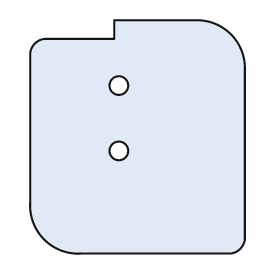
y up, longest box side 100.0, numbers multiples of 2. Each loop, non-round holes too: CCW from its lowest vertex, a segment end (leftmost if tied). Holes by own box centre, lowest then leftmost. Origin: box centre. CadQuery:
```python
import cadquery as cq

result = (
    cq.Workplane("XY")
    .moveTo(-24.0, -50.0)
    .lineTo(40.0, -50.0)
    .threePointArc((44.0, -48.0), (46.0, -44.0))
    .lineTo(46.0, 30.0)
    .threePointArc((40.0, 44.0), (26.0, 50.0))
    .lineTo(-10.0, 50.0)
    .lineTo(-10.0, 42.0)
    .lineTo(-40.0, 42.0)
    .threePointArc((-44.0, 40.0), (-46.0, 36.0))
    .lineTo(-46.0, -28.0)
    .threePointArc((-40.0, -44.0), (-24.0, -50.0))
    .close()
    .moveTo(-8.0, -6.0)
    .circle(4.0)
    .moveTo(-8.0, 22.0)
    .circle(4.0)
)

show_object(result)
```